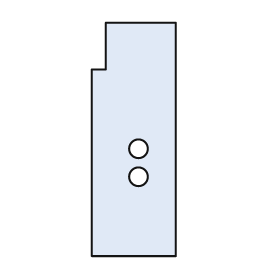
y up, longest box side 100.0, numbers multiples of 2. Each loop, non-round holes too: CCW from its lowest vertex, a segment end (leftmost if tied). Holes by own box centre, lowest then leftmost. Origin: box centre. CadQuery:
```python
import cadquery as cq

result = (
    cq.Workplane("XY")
    .moveTo(-18.0, -50.0)
    .lineTo(18.0, -50.0)
    .lineTo(18.0, 50.0)
    .lineTo(-12.0, 50.0)
    .lineTo(-12.0, 30.0)
    .lineTo(-18.0, 30.0)
    .close()
    .moveTo(2.0, -16.0)
    .circle(4.0)
    .moveTo(2.0, -4.0)
    .circle(4.0)
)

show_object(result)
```